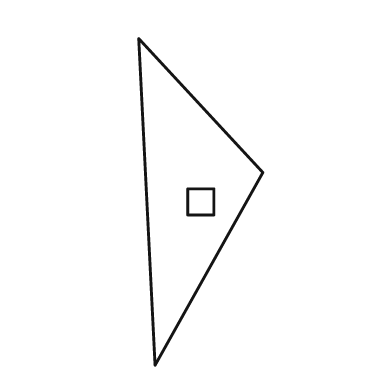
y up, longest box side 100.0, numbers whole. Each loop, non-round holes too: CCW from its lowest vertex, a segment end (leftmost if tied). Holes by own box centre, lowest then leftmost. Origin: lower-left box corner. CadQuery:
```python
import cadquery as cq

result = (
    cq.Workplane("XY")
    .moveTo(5.0, 0.0)
    .lineTo(38.0, 59.0)
    .lineTo(0.0, 100.0)
    .close()
    .moveTo(15.0, 46.0)
    .lineTo(23.0, 46.0)
    .lineTo(23.0, 54.0)
    .lineTo(15.0, 54.0)
    .close()
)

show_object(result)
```